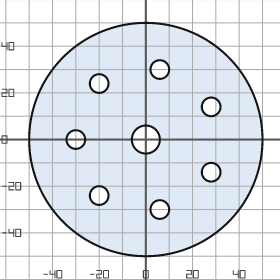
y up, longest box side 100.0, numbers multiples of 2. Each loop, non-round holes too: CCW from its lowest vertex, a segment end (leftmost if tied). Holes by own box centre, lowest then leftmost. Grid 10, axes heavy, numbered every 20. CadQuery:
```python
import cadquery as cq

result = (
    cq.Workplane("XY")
    .moveTo(0.0, 0.0)
    .circle(50.0)
    .moveTo(6.0, -30.0)
    .circle(4.0)
    .moveTo(-20.0, -24.0)
    .circle(4.0)
    .moveTo(28.0, -14.0)
    .circle(4.0)
    .moveTo(-30.0, 0.0)
    .circle(4.0)
    .moveTo(0.0, 0.0)
    .circle(6.0)
    .moveTo(28.0, 14.0)
    .circle(4.0)
    .moveTo(-20.0, 24.0)
    .circle(4.0)
    .moveTo(6.0, 30.0)
    .circle(4.0)
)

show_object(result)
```